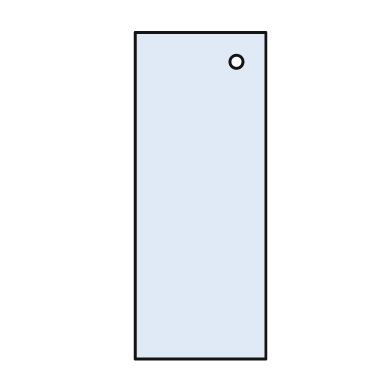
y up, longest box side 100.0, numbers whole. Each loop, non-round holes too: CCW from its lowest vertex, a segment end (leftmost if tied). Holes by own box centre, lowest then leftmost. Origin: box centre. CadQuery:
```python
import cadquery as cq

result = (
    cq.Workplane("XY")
    .moveTo(-20.0, -50.0)
    .lineTo(20.0, -50.0)
    .lineTo(20.0, 50.0)
    .lineTo(-20.0, 50.0)
    .close()
    .moveTo(11.0, 41.0)
    .circle(2.0)
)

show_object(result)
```